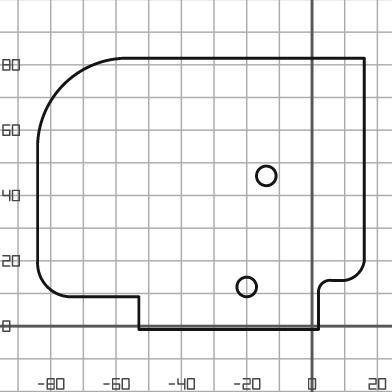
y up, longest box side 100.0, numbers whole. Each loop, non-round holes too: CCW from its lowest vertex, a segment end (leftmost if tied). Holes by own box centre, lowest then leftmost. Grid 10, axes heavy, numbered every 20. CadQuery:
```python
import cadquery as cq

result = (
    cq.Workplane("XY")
    .moveTo(-53.0, -1.0)
    .lineTo(2.0, -1.0)
    .lineTo(2.0, 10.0)
    .threePointArc((3.0, 13.0), (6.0, 14.0))
    .lineTo(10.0, 14.0)
    .threePointArc((14.0, 16.0), (16.0, 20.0))
    .lineTo(16.0, 82.0)
    .lineTo(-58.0, 82.0)
    .threePointArc((-76.0, 74.0), (-84.0, 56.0))
    .lineTo(-84.0, 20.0)
    .threePointArc((-81.0, 12.0), (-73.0, 9.0))
    .lineTo(-53.0, 9.0)
    .close()
    .moveTo(-20.0, 12.0)
    .circle(3.0)
    .moveTo(-14.0, 46.0)
    .circle(3.0)
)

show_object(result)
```